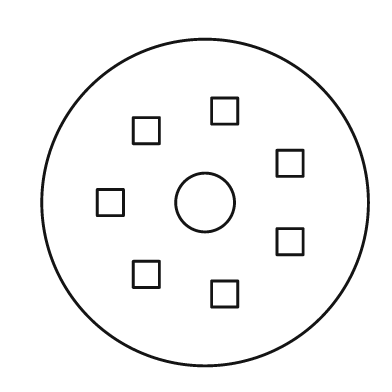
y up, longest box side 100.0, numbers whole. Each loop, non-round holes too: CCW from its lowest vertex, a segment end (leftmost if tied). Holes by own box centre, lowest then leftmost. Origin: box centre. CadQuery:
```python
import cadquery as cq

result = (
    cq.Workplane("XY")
    .moveTo(0.0, 0.0)
    .circle(50.0)
    .moveTo(2.0, -32.0)
    .lineTo(10.0, -32.0)
    .lineTo(10.0, -24.0)
    .lineTo(2.0, -24.0)
    .close()
    .moveTo(-22.0, -26.0)
    .lineTo(-14.0, -26.0)
    .lineTo(-14.0, -18.0)
    .lineTo(-22.0, -18.0)
    .close()
    .moveTo(22.0, -16.0)
    .lineTo(30.0, -16.0)
    .lineTo(30.0, -8.0)
    .lineTo(22.0, -8.0)
    .close()
    .moveTo(-33.0, -4.0)
    .lineTo(-25.0, -4.0)
    .lineTo(-25.0, 4.0)
    .lineTo(-33.0, 4.0)
    .close()
    .moveTo(0.0, 0.0)
    .circle(9.0)
    .moveTo(22.0, 8.0)
    .lineTo(30.0, 8.0)
    .lineTo(30.0, 16.0)
    .lineTo(22.0, 16.0)
    .close()
    .moveTo(-22.0, 18.0)
    .lineTo(-14.0, 18.0)
    .lineTo(-14.0, 26.0)
    .lineTo(-22.0, 26.0)
    .close()
    .moveTo(2.0, 24.0)
    .lineTo(10.0, 24.0)
    .lineTo(10.0, 32.0)
    .lineTo(2.0, 32.0)
    .close()
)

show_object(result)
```